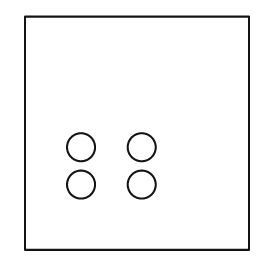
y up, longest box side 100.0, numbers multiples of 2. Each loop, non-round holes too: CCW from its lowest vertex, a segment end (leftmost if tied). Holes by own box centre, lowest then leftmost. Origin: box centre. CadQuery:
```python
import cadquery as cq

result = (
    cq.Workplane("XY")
    .moveTo(-48.0, -50.0)
    .lineTo(48.0, -50.0)
    .lineTo(48.0, 50.0)
    .lineTo(-48.0, 50.0)
    .close()
    .moveTo(-24.0, -22.0)
    .circle(6.0)
    .moveTo(2.0, -22.0)
    .circle(6.0)
    .moveTo(-24.0, -6.0)
    .circle(6.0)
    .moveTo(2.0, -6.0)
    .circle(6.0)
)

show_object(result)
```